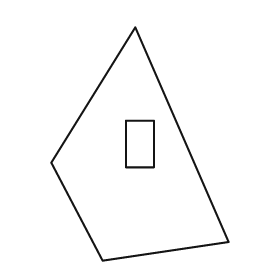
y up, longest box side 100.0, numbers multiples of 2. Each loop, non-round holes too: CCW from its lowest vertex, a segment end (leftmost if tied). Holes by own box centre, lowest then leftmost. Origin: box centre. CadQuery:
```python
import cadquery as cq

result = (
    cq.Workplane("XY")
    .moveTo(-16.0, -50.0)
    .lineTo(38.0, -42.0)
    .lineTo(-2.0, 50.0)
    .lineTo(-38.0, -8.0)
    .close()
    .moveTo(-6.0, -10.0)
    .lineTo(6.0, -10.0)
    .lineTo(6.0, 10.0)
    .lineTo(-6.0, 10.0)
    .close()
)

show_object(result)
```